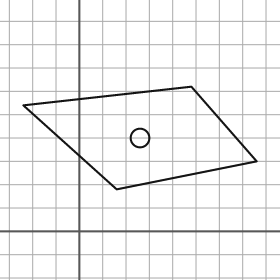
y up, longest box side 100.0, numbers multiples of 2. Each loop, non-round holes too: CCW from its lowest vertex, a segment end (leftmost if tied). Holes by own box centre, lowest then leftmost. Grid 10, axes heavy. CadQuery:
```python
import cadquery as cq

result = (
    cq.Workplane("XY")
    .moveTo(16.0, 18.0)
    .lineTo(76.0, 30.0)
    .lineTo(48.0, 62.0)
    .lineTo(-24.0, 54.0)
    .close()
    .moveTo(26.0, 40.0)
    .circle(4.0)
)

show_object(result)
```